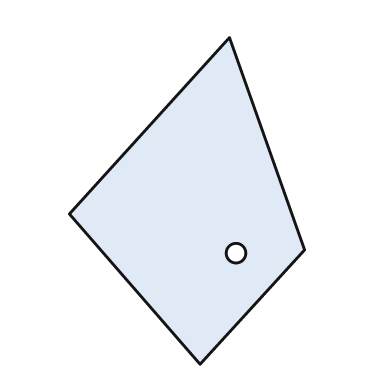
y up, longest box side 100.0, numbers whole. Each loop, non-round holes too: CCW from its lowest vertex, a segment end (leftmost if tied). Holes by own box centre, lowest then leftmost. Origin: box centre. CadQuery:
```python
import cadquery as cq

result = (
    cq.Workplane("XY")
    .moveTo(4.0, -50.0)
    .lineTo(36.0, -15.0)
    .lineTo(13.0, 50.0)
    .lineTo(-36.0, -4.0)
    .close()
    .moveTo(15.0, -16.0)
    .circle(3.0)
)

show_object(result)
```